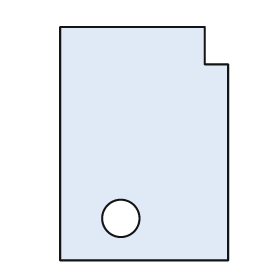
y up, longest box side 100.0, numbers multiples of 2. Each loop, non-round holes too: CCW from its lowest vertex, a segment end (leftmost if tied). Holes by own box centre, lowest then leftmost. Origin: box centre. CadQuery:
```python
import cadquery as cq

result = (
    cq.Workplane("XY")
    .moveTo(-36.0, -50.0)
    .lineTo(36.0, -50.0)
    .lineTo(36.0, 34.0)
    .lineTo(26.0, 34.0)
    .lineTo(26.0, 50.0)
    .lineTo(-36.0, 50.0)
    .close()
    .moveTo(-10.0, -32.0)
    .circle(8.0)
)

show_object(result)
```